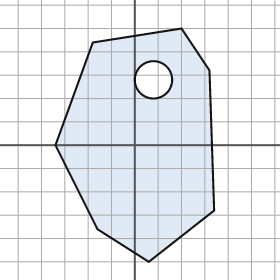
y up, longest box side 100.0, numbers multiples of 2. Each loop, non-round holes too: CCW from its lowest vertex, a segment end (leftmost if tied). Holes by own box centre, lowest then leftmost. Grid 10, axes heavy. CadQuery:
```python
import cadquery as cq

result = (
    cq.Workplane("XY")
    .moveTo(6.0, -50.0)
    .lineTo(34.0, -28.0)
    .lineTo(32.0, 32.0)
    .lineTo(20.0, 50.0)
    .lineTo(-18.0, 44.0)
    .lineTo(-34.0, 0.0)
    .lineTo(-16.0, -36.0)
    .close()
    .moveTo(8.0, 28.0)
    .circle(8.0)
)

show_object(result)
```